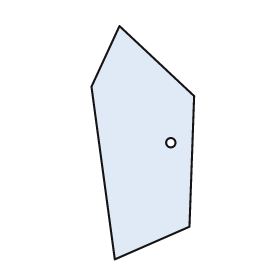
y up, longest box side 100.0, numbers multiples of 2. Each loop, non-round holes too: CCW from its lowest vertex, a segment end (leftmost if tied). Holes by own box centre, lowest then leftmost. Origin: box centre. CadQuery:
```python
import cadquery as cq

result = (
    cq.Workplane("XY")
    .moveTo(-12.0, -50.0)
    .lineTo(20.0, -36.0)
    .lineTo(22.0, 20.0)
    .lineTo(-10.0, 50.0)
    .lineTo(-22.0, 24.0)
    .close()
    .moveTo(12.0, 0.0)
    .circle(2.0)
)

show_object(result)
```